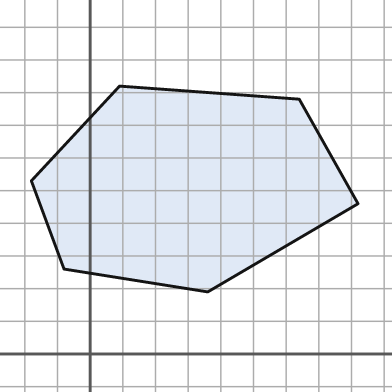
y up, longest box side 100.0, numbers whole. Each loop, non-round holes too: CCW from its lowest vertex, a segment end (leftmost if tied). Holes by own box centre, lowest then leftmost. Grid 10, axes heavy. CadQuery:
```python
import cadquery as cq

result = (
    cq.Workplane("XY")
    .moveTo(36.0, 19.0)
    .lineTo(82.0, 46.0)
    .lineTo(64.0, 78.0)
    .lineTo(9.0, 82.0)
    .lineTo(-18.0, 53.0)
    .lineTo(-8.0, 26.0)
    .close()
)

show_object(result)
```